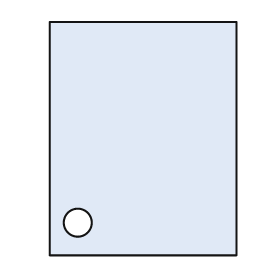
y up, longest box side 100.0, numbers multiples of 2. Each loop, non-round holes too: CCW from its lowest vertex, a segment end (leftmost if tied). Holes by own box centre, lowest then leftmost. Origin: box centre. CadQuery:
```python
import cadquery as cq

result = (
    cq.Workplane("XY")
    .moveTo(-40.0, -50.0)
    .lineTo(40.0, -50.0)
    .lineTo(40.0, 50.0)
    .lineTo(-40.0, 50.0)
    .close()
    .moveTo(-28.0, -36.0)
    .circle(6.0)
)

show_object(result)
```